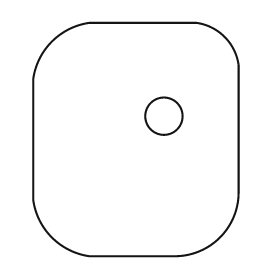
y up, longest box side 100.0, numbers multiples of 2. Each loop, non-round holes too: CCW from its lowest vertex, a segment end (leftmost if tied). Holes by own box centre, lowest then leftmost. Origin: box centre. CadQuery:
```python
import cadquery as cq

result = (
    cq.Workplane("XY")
    .moveTo(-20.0, -50.0)
    .lineTo(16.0, -50.0)
    .threePointArc((36.0, -42.0), (44.0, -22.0))
    .lineTo(44.0, 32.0)
    .threePointArc((38.0, 44.0), (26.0, 50.0))
    .lineTo(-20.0, 50.0)
    .threePointArc((-36.0, 42.0), (-44.0, 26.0))
    .lineTo(-44.0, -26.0)
    .threePointArc((-36.0, -42.0), (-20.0, -50.0))
    .close()
    .moveTo(12.0, 10.0)
    .circle(8.0)
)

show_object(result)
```